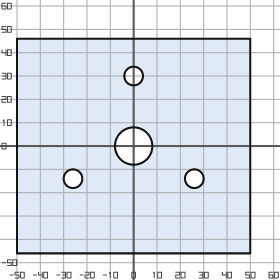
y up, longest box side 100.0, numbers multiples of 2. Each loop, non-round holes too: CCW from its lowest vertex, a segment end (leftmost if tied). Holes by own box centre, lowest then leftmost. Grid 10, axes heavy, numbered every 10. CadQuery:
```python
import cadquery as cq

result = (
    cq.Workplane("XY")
    .moveTo(-50.0, -46.0)
    .lineTo(50.0, -46.0)
    .lineTo(50.0, 46.0)
    .lineTo(-50.0, 46.0)
    .close()
    .moveTo(-26.0, -14.0)
    .circle(4.0)
    .moveTo(26.0, -14.0)
    .circle(4.0)
    .moveTo(0.0, 0.0)
    .circle(8.0)
    .moveTo(0.0, 30.0)
    .circle(4.0)
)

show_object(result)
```